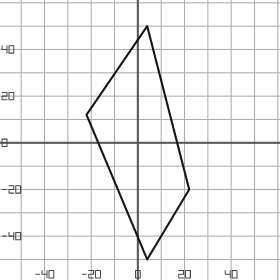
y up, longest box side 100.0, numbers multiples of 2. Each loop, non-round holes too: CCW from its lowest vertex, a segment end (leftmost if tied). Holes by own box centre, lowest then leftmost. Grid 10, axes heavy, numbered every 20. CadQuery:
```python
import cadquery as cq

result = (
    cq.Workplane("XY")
    .moveTo(4.0, -50.0)
    .lineTo(22.0, -20.0)
    .lineTo(4.0, 50.0)
    .lineTo(-22.0, 12.0)
    .close()
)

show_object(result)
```